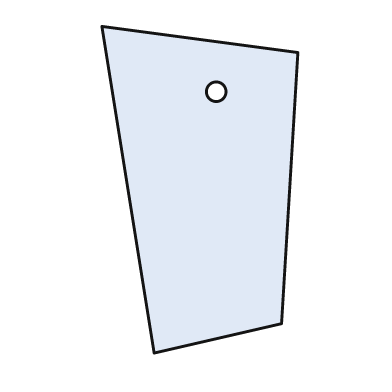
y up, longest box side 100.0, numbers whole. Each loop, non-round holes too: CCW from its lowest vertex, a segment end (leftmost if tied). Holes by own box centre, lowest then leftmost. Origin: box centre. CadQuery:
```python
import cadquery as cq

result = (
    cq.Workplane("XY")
    .moveTo(-14.0, -50.0)
    .lineTo(25.0, -41.0)
    .lineTo(30.0, 42.0)
    .lineTo(-30.0, 50.0)
    .close()
    .moveTo(5.0, 30.0)
    .circle(3.0)
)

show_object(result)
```